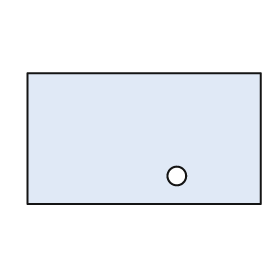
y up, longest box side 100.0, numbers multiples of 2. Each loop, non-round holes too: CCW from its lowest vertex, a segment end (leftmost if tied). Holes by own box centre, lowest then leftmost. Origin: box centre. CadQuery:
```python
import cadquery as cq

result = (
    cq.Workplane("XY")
    .moveTo(-50.0, -28.0)
    .lineTo(50.0, -28.0)
    .lineTo(50.0, 28.0)
    .lineTo(-50.0, 28.0)
    .close()
    .moveTo(14.0, -16.0)
    .circle(4.0)
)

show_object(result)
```